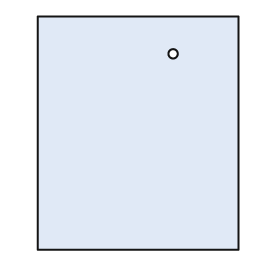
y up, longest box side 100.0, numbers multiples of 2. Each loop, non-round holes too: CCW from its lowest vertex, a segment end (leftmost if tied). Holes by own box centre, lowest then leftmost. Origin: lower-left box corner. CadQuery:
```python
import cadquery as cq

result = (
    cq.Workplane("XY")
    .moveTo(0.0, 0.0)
    .lineTo(86.0, 0.0)
    .lineTo(86.0, 100.0)
    .lineTo(0.0, 100.0)
    .close()
    .moveTo(58.0, 84.0)
    .circle(2.0)
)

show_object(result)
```